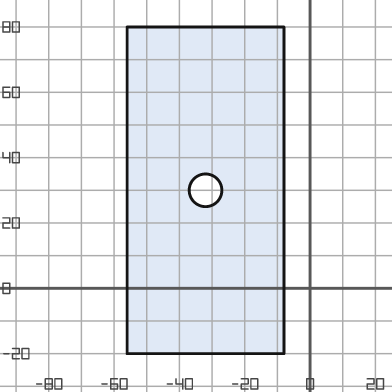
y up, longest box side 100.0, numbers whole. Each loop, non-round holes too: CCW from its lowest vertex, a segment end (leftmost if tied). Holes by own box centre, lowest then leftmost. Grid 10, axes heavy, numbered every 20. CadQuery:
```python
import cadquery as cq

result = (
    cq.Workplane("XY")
    .moveTo(-56.0, -20.0)
    .lineTo(-8.0, -20.0)
    .lineTo(-8.0, 80.0)
    .lineTo(-56.0, 80.0)
    .close()
    .moveTo(-32.0, 30.0)
    .circle(5.0)
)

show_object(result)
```